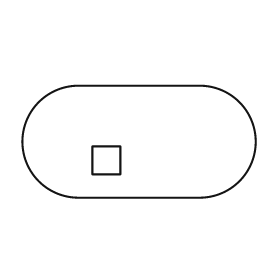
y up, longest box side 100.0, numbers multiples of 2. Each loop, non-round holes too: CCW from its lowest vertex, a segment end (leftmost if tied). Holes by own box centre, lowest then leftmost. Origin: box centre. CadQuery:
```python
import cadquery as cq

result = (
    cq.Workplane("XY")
    .moveTo(-26.0, -24.0)
    .lineTo(26.0, -24.0)
    .threePointArc((50.0, 0.0), (26.0, 24.0))
    .lineTo(-26.0, 24.0)
    .threePointArc((-50.0, 0.0), (-26.0, -24.0))
    .close()
    .moveTo(-20.0, -14.0)
    .lineTo(-8.0, -14.0)
    .lineTo(-8.0, -2.0)
    .lineTo(-20.0, -2.0)
    .close()
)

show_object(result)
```